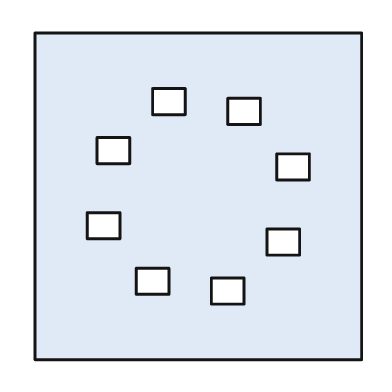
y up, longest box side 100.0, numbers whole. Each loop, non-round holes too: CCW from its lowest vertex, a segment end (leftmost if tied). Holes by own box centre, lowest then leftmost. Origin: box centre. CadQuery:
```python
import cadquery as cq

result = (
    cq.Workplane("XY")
    .moveTo(-50.0, -50.0)
    .lineTo(50.0, -50.0)
    .lineTo(50.0, 50.0)
    .lineTo(-50.0, 50.0)
    .close()
    .moveTo(4.0, -33.0)
    .lineTo(14.0, -33.0)
    .lineTo(14.0, -25.0)
    .lineTo(4.0, -25.0)
    .close()
    .moveTo(-19.0, -30.0)
    .lineTo(-9.0, -30.0)
    .lineTo(-9.0, -22.0)
    .lineTo(-19.0, -22.0)
    .close()
    .moveTo(21.0, -18.0)
    .lineTo(31.0, -18.0)
    .lineTo(31.0, -10.0)
    .lineTo(21.0, -10.0)
    .close()
    .moveTo(-34.0, -13.0)
    .lineTo(-24.0, -13.0)
    .lineTo(-24.0, -5.0)
    .lineTo(-34.0, -5.0)
    .close()
    .moveTo(24.0, 5.0)
    .lineTo(34.0, 5.0)
    .lineTo(34.0, 13.0)
    .lineTo(24.0, 13.0)
    .close()
    .moveTo(-31.0, 10.0)
    .lineTo(-21.0, 10.0)
    .lineTo(-21.0, 18.0)
    .lineTo(-31.0, 18.0)
    .close()
    .moveTo(9.0, 22.0)
    .lineTo(19.0, 22.0)
    .lineTo(19.0, 30.0)
    .lineTo(9.0, 30.0)
    .close()
    .moveTo(-14.0, 25.0)
    .lineTo(-4.0, 25.0)
    .lineTo(-4.0, 33.0)
    .lineTo(-14.0, 33.0)
    .close()
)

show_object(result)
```